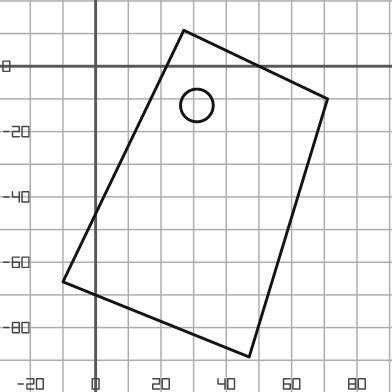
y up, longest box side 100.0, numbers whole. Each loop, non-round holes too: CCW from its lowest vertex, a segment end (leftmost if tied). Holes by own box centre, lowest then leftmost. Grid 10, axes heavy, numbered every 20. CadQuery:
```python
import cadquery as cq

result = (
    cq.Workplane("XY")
    .moveTo(47.0, -89.0)
    .lineTo(71.0, -10.0)
    .lineTo(27.0, 11.0)
    .lineTo(-10.0, -66.0)
    .close()
    .moveTo(31.0, -12.0)
    .circle(5.0)
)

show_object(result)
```